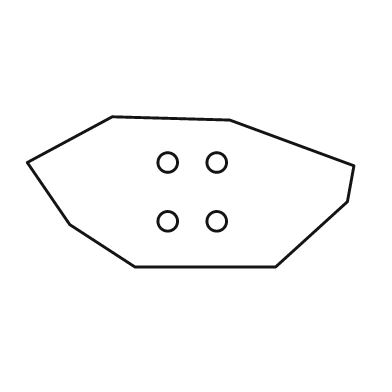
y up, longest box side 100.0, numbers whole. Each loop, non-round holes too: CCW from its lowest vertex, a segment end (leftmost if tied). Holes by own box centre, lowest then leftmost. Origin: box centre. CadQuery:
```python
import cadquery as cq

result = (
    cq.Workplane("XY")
    .moveTo(-17.0, -23.0)
    .lineTo(26.0, -23.0)
    .lineTo(48.0, -3.0)
    .lineTo(50.0, 8.0)
    .lineTo(12.0, 22.0)
    .lineTo(-24.0, 23.0)
    .lineTo(-50.0, 9.0)
    .lineTo(-37.0, -10.0)
    .close()
    .moveTo(-7.0, -9.0)
    .circle(3.0)
    .moveTo(8.0, -9.0)
    .circle(3.0)
    .moveTo(-7.0, 9.0)
    .circle(3.0)
    .moveTo(8.0, 9.0)
    .circle(3.0)
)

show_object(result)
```